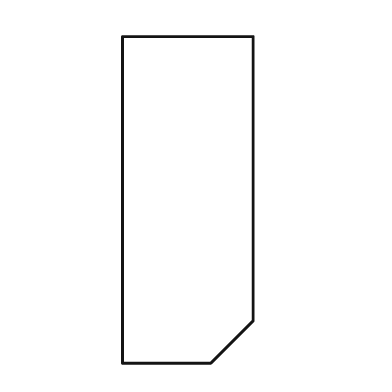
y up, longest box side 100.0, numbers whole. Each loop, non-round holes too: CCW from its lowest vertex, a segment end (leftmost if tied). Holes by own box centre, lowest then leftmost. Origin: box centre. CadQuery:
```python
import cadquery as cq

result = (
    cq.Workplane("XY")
    .moveTo(-20.0, -50.0)
    .lineTo(7.0, -50.0)
    .lineTo(20.0, -37.0)
    .lineTo(20.0, 50.0)
    .lineTo(-20.0, 50.0)
    .close()
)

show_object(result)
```